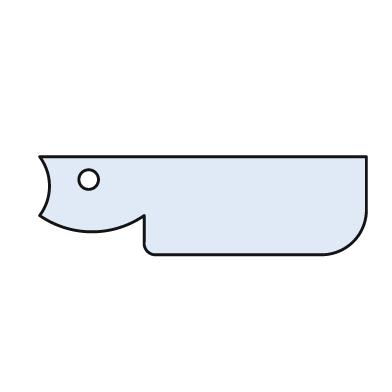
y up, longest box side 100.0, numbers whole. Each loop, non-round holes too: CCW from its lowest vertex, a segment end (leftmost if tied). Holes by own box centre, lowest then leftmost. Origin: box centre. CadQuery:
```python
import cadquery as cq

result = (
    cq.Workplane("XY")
    .moveTo(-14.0, -15.0)
    .lineTo(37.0, -15.0)
    .threePointArc((46.0, -11.0), (50.0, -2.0))
    .lineTo(50.0, 15.0)
    .lineTo(-50.0, 15.0)
    .threePointArc((-47.0, 6.0), (-50.0, -3.0))
    .threePointArc((-34.0, -8.0), (-18.0, -3.0))
    .lineTo(-18.0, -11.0)
    .threePointArc((-17.0, -14.0), (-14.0, -15.0))
    .close()
    .moveTo(-35.0, 8.0)
    .circle(3.0)
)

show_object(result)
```